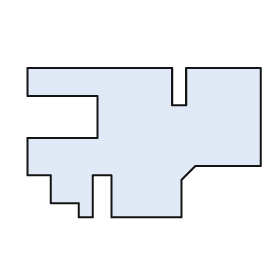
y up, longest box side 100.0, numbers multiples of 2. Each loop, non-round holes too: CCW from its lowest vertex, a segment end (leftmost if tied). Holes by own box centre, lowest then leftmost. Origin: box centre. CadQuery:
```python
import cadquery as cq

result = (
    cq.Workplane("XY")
    .moveTo(-28.0, -32.0)
    .lineTo(-22.0, -32.0)
    .lineTo(-22.0, -14.0)
    .lineTo(-14.0, -14.0)
    .lineTo(-14.0, -32.0)
    .lineTo(16.0, -32.0)
    .lineTo(16.0, -16.0)
    .lineTo(22.0, -10.0)
    .lineTo(50.0, -10.0)
    .lineTo(50.0, 32.0)
    .lineTo(18.0, 32.0)
    .lineTo(18.0, 16.0)
    .lineTo(12.0, 16.0)
    .lineTo(12.0, 32.0)
    .lineTo(-50.0, 32.0)
    .lineTo(-50.0, 20.0)
    .lineTo(-20.0, 20.0)
    .lineTo(-20.0, 2.0)
    .lineTo(-50.0, 2.0)
    .lineTo(-50.0, -14.0)
    .lineTo(-40.0, -14.0)
    .lineTo(-40.0, -26.0)
    .lineTo(-28.0, -26.0)
    .close()
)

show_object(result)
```